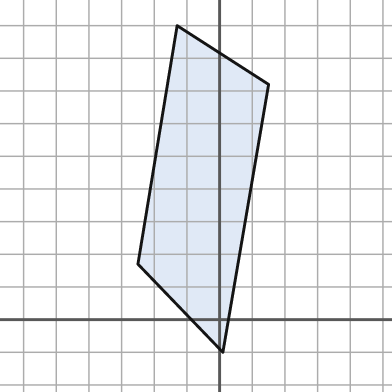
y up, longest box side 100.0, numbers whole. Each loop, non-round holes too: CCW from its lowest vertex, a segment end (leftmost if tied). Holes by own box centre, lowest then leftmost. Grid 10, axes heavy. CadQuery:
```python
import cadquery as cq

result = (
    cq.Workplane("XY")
    .moveTo(1.0, -10.0)
    .lineTo(15.0, 72.0)
    .lineTo(-13.0, 90.0)
    .lineTo(-25.0, 17.0)
    .close()
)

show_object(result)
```